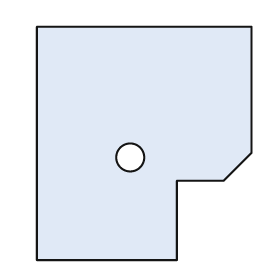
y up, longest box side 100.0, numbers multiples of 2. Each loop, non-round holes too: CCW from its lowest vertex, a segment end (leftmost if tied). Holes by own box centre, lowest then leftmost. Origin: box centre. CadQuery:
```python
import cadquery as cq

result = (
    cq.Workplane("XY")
    .moveTo(-46.0, -50.0)
    .lineTo(14.0, -50.0)
    .lineTo(14.0, -16.0)
    .lineTo(34.0, -16.0)
    .lineTo(46.0, -4.0)
    .lineTo(46.0, 50.0)
    .lineTo(-46.0, 50.0)
    .close()
    .moveTo(-6.0, -6.0)
    .circle(6.0)
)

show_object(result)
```